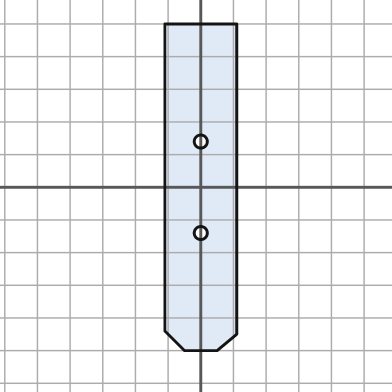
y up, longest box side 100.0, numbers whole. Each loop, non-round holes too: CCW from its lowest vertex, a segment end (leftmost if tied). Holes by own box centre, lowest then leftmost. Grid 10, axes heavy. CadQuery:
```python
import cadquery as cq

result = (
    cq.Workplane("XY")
    .moveTo(-5.0, -50.0)
    .lineTo(5.0, -50.0)
    .lineTo(11.0, -45.0)
    .lineTo(11.0, 50.0)
    .lineTo(-11.0, 50.0)
    .lineTo(-11.0, -44.0)
    .close()
    .moveTo(0.0, -14.0)
    .circle(2.0)
    .moveTo(0.0, 14.0)
    .circle(2.0)
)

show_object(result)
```